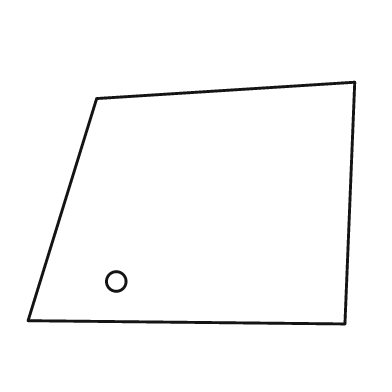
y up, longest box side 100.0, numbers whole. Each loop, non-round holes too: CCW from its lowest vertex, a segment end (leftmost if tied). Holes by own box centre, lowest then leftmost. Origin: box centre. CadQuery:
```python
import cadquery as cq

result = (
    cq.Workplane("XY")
    .moveTo(47.0, -37.0)
    .lineTo(50.0, 37.0)
    .lineTo(-29.0, 32.0)
    .lineTo(-50.0, -36.0)
    .close()
    .moveTo(-23.0, -24.0)
    .circle(3.0)
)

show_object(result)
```